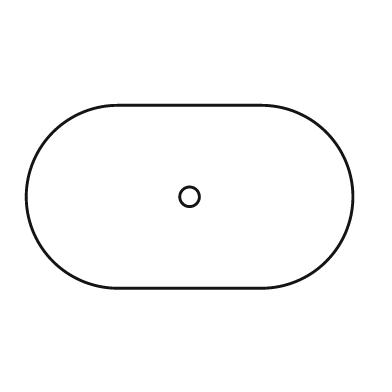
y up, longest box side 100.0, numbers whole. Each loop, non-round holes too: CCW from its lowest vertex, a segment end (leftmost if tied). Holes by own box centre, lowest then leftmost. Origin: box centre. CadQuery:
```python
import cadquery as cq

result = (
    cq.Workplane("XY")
    .moveTo(-22.0, -28.0)
    .lineTo(22.0, -28.0)
    .threePointArc((50.0, 0.0), (22.0, 28.0))
    .lineTo(-22.0, 28.0)
    .threePointArc((-50.0, 0.0), (-22.0, -28.0))
    .close()
    .moveTo(0.0, 0.0)
    .circle(3.0)
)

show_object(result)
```